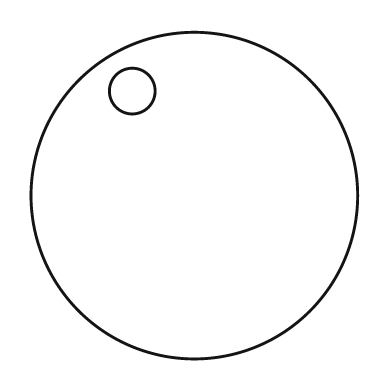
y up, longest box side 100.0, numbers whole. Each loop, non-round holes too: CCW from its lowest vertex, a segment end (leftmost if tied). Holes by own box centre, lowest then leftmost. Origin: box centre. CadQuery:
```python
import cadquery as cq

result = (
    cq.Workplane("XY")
    .moveTo(0.0, 0.0)
    .circle(50.0)
    .moveTo(-19.0, 32.0)
    .circle(7.0)
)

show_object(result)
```